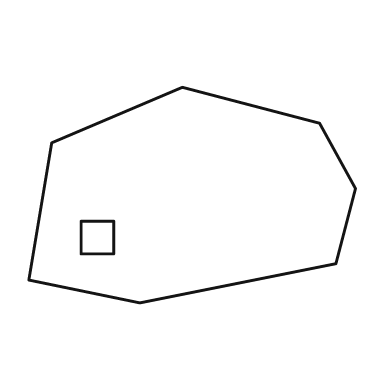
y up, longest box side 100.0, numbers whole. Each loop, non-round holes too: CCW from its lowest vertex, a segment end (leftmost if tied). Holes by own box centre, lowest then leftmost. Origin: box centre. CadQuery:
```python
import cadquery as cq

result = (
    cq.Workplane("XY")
    .moveTo(-16.0, -33.0)
    .lineTo(44.0, -21.0)
    .lineTo(50.0, 2.0)
    .lineTo(39.0, 22.0)
    .lineTo(-3.0, 33.0)
    .lineTo(-43.0, 16.0)
    .lineTo(-50.0, -26.0)
    .close()
    .moveTo(-34.0, -18.0)
    .lineTo(-24.0, -18.0)
    .lineTo(-24.0, -8.0)
    .lineTo(-34.0, -8.0)
    .close()
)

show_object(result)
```